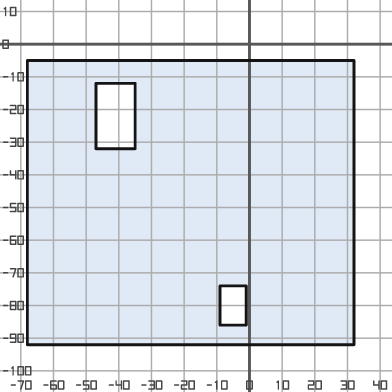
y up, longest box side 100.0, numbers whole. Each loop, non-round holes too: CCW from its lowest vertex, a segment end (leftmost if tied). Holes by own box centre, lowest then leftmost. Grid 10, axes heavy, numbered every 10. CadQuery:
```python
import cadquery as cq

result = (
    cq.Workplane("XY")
    .moveTo(-68.0, -92.0)
    .lineTo(32.0, -92.0)
    .lineTo(32.0, -5.0)
    .lineTo(-68.0, -5.0)
    .close()
    .moveTo(-9.0, -86.0)
    .lineTo(-1.0, -86.0)
    .lineTo(-1.0, -74.0)
    .lineTo(-9.0, -74.0)
    .close()
    .moveTo(-47.0, -32.0)
    .lineTo(-35.0, -32.0)
    .lineTo(-35.0, -12.0)
    .lineTo(-47.0, -12.0)
    .close()
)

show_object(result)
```